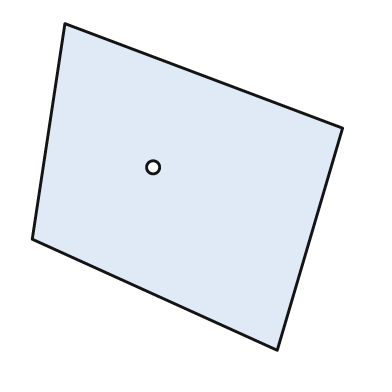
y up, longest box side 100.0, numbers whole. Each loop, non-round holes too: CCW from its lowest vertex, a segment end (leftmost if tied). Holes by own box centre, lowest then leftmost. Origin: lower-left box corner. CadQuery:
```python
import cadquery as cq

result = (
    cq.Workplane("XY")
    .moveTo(75.0, 0.0)
    .lineTo(95.0, 68.0)
    .lineTo(10.0, 100.0)
    .lineTo(0.0, 34.0)
    .close()
    .moveTo(37.0, 56.0)
    .circle(2.0)
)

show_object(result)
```